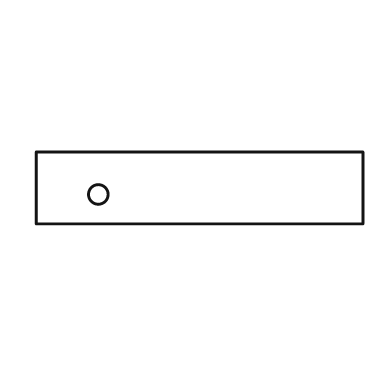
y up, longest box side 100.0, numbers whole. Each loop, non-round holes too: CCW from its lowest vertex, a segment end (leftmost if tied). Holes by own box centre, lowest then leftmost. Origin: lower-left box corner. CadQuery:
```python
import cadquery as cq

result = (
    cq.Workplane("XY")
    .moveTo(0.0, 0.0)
    .lineTo(100.0, 0.0)
    .lineTo(100.0, 22.0)
    .lineTo(0.0, 22.0)
    .close()
    .moveTo(19.0, 9.0)
    .circle(3.0)
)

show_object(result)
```